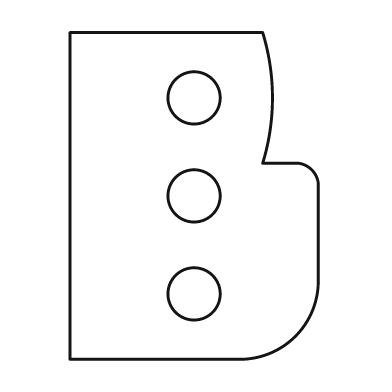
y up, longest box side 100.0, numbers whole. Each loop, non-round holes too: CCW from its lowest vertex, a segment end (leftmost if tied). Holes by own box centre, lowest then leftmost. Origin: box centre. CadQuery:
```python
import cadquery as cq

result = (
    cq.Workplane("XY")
    .moveTo(-38.0, -50.0)
    .lineTo(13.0, -50.0)
    .threePointArc((31.0, -43.0), (38.0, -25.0))
    .lineTo(38.0, 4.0)
    .threePointArc((36.0, 8.0), (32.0, 10.0))
    .lineTo(21.0, 10.0)
    .threePointArc((24.0, 30.0), (21.0, 50.0))
    .lineTo(-38.0, 50.0)
    .close()
    .moveTo(0.0, -30.0)
    .circle(8.0)
    .moveTo(0.0, 0.0)
    .circle(8.0)
    .moveTo(0.0, 30.0)
    .circle(8.0)
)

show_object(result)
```